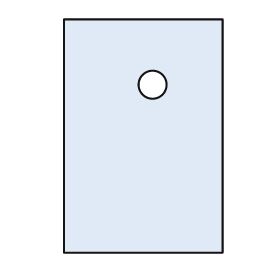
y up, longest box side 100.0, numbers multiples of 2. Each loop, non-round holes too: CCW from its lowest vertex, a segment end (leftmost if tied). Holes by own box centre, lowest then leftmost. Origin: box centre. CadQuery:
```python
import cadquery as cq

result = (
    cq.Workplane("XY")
    .moveTo(-34.0, -50.0)
    .lineTo(34.0, -50.0)
    .lineTo(34.0, 50.0)
    .lineTo(-34.0, 50.0)
    .close()
    .moveTo(4.0, 22.0)
    .circle(6.0)
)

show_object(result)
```